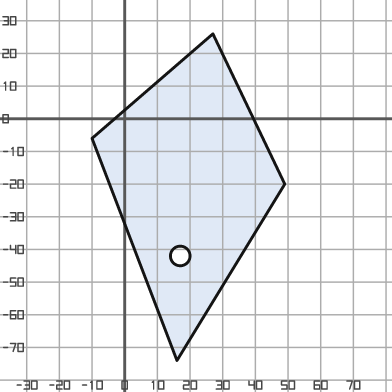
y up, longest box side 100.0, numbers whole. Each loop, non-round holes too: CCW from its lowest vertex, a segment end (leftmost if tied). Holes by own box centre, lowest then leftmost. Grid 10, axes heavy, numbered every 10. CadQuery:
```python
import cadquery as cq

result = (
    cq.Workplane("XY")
    .moveTo(16.0, -74.0)
    .lineTo(49.0, -20.0)
    .lineTo(27.0, 26.0)
    .lineTo(-10.0, -6.0)
    .close()
    .moveTo(17.0, -42.0)
    .circle(3.0)
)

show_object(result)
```